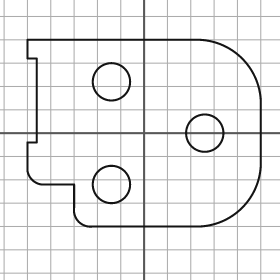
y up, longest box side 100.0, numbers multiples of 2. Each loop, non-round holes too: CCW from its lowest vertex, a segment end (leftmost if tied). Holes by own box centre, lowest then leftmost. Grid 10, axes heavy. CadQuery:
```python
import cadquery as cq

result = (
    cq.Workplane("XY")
    .moveTo(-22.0, -40.0)
    .lineTo(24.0, -40.0)
    .threePointArc((42.0, -32.0), (50.0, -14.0))
    .lineTo(50.0, 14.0)
    .threePointArc((42.0, 32.0), (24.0, 40.0))
    .lineTo(-50.0, 40.0)
    .lineTo(-50.0, 32.0)
    .lineTo(-46.0, 32.0)
    .lineTo(-46.0, -4.0)
    .lineTo(-50.0, -4.0)
    .lineTo(-50.0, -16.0)
    .threePointArc((-48.0, -20.0), (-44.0, -22.0))
    .lineTo(-30.0, -22.0)
    .lineTo(-30.0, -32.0)
    .threePointArc((-28.0, -38.0), (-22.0, -40.0))
    .close()
    .moveTo(-14.0, -22.0)
    .circle(8.0)
    .moveTo(26.0, 0.0)
    .circle(8.0)
    .moveTo(-14.0, 22.0)
    .circle(8.0)
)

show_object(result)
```